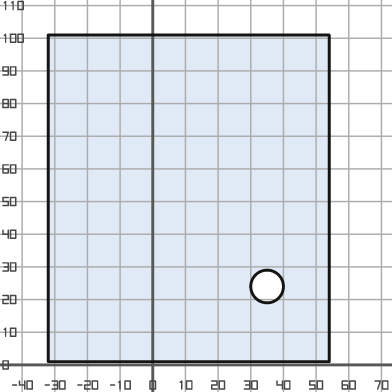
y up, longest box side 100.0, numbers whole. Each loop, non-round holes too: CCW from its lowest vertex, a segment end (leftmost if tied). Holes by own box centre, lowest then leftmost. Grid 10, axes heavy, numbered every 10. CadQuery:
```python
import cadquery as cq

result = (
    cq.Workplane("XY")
    .moveTo(-32.0, 1.0)
    .lineTo(54.0, 1.0)
    .lineTo(54.0, 101.0)
    .lineTo(-32.0, 101.0)
    .close()
    .moveTo(35.0, 24.0)
    .circle(5.0)
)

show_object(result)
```